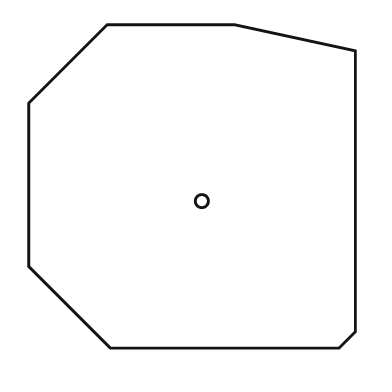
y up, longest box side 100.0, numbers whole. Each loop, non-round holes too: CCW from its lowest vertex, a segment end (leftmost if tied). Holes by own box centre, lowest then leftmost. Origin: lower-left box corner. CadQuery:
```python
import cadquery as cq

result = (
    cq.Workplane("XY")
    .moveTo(25.0, 0.0)
    .lineTo(95.0, 0.0)
    .lineTo(100.0, 5.0)
    .lineTo(100.0, 91.0)
    .lineTo(63.0, 99.0)
    .lineTo(24.0, 99.0)
    .lineTo(0.0, 75.0)
    .lineTo(0.0, 25.0)
    .close()
    .moveTo(53.0, 45.0)
    .circle(2.0)
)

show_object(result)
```